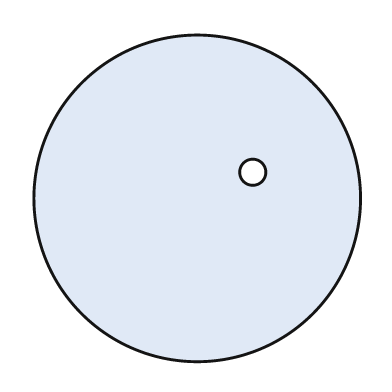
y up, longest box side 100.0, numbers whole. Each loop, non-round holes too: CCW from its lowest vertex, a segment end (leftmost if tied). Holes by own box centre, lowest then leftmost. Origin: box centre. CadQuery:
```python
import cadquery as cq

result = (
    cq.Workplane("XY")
    .moveTo(0.0, 0.0)
    .circle(50.0)
    .moveTo(17.0, 8.0)
    .circle(4.0)
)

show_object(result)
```